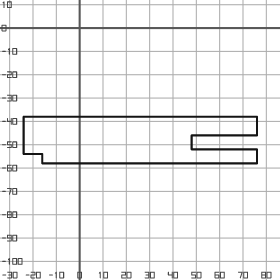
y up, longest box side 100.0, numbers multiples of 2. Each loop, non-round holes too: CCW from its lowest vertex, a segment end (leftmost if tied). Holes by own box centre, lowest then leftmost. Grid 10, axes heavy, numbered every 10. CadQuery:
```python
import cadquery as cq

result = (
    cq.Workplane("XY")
    .moveTo(-16.0, -58.0)
    .lineTo(76.0, -58.0)
    .lineTo(76.0, -52.0)
    .lineTo(48.0, -52.0)
    .lineTo(48.0, -46.0)
    .lineTo(76.0, -46.0)
    .lineTo(76.0, -38.0)
    .lineTo(-24.0, -38.0)
    .lineTo(-24.0, -54.0)
    .lineTo(-16.0, -54.0)
    .close()
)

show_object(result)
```